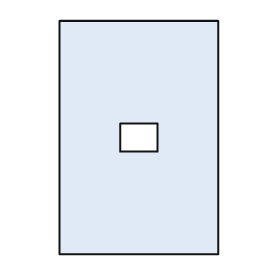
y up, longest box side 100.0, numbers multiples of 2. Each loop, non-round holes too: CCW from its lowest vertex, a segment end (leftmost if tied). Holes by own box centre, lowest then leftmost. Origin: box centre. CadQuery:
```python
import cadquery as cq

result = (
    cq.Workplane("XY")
    .moveTo(-34.0, -50.0)
    .lineTo(34.0, -50.0)
    .lineTo(34.0, 50.0)
    .lineTo(-34.0, 50.0)
    .close()
    .moveTo(-8.0, -6.0)
    .lineTo(8.0, -6.0)
    .lineTo(8.0, 6.0)
    .lineTo(-8.0, 6.0)
    .close()
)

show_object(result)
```